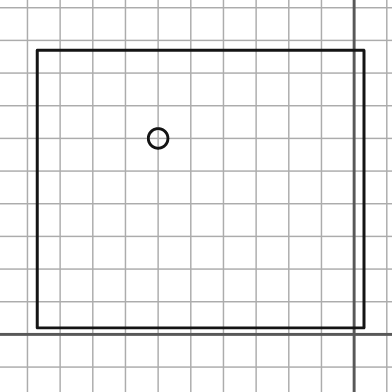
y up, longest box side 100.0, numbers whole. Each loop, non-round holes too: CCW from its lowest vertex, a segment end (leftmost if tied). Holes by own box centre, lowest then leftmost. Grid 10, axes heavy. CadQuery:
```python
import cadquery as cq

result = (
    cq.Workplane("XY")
    .moveTo(-97.0, 2.0)
    .lineTo(3.0, 2.0)
    .lineTo(3.0, 87.0)
    .lineTo(-97.0, 87.0)
    .close()
    .moveTo(-60.0, 60.0)
    .circle(3.0)
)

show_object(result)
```